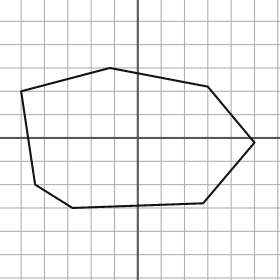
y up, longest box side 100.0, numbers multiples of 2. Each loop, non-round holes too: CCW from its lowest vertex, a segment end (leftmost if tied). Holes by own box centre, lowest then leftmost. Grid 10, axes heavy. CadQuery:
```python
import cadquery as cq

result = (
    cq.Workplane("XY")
    .moveTo(-28.0, -30.0)
    .lineTo(28.0, -28.0)
    .lineTo(50.0, -2.0)
    .lineTo(30.0, 22.0)
    .lineTo(-12.0, 30.0)
    .lineTo(-50.0, 20.0)
    .lineTo(-44.0, -20.0)
    .close()
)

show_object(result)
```